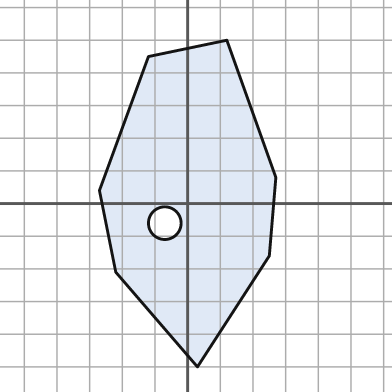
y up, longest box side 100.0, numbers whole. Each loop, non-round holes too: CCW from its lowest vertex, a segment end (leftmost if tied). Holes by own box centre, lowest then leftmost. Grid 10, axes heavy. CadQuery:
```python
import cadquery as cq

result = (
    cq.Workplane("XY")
    .moveTo(3.0, -50.0)
    .lineTo(25.0, -16.0)
    .lineTo(27.0, 8.0)
    .lineTo(12.0, 50.0)
    .lineTo(-12.0, 45.0)
    .lineTo(-27.0, 4.0)
    .lineTo(-22.0, -21.0)
    .close()
    .moveTo(-7.0, -6.0)
    .circle(5.0)
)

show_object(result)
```